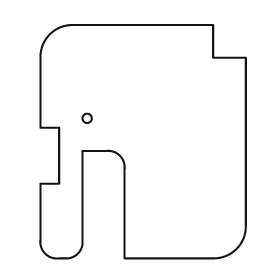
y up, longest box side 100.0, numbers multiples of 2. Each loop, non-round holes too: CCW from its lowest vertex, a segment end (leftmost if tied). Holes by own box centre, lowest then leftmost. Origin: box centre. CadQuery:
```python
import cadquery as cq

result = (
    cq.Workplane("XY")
    .moveTo(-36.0, -50.0)
    .lineTo(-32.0, -50.0)
    .threePointArc((-28.0, -48.0), (-26.0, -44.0))
    .lineTo(-26.0, -4.0)
    .lineTo(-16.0, -4.0)
    .threePointArc((-10.0, -6.0), (-8.0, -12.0))
    .lineTo(-8.0, -50.0)
    .lineTo(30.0, -50.0)
    .threePointArc((40.0, -46.0), (44.0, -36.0))
    .lineTo(44.0, 36.0)
    .lineTo(30.0, 36.0)
    .lineTo(30.0, 50.0)
    .lineTo(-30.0, 50.0)
    .threePointArc((-40.0, 46.0), (-44.0, 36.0))
    .lineTo(-44.0, 6.0)
    .lineTo(-36.0, 6.0)
    .lineTo(-36.0, -18.0)
    .lineTo(-44.0, -18.0)
    .lineTo(-44.0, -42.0)
    .threePointArc((-42.0, -48.0), (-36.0, -50.0))
    .close()
    .moveTo(-24.0, 10.0)
    .circle(2.0)
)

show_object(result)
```